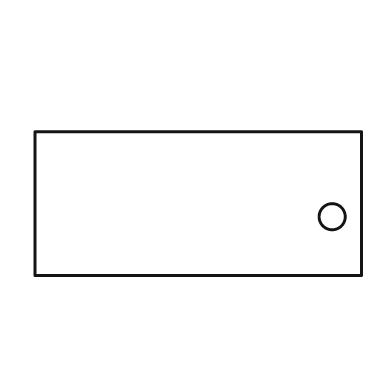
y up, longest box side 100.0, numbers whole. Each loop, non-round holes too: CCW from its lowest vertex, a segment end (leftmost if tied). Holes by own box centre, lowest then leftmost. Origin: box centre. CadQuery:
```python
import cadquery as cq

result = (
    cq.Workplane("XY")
    .moveTo(-50.0, -22.0)
    .lineTo(50.0, -22.0)
    .lineTo(50.0, 22.0)
    .lineTo(-50.0, 22.0)
    .close()
    .moveTo(41.0, -4.0)
    .circle(4.0)
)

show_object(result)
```